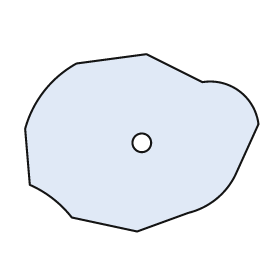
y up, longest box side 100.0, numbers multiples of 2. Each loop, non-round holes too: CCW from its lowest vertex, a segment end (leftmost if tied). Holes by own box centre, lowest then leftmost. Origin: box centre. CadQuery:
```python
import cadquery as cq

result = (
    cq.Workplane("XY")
    .moveTo(-2.0, -38.0)
    .lineTo(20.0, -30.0)
    .threePointArc((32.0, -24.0), (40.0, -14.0))
    .lineTo(50.0, 8.0)
    .threePointArc((42.0, 22.0), (26.0, 26.0))
    .lineTo(2.0, 38.0)
    .lineTo(-28.0, 34.0)
    .threePointArc((-42.0, 22.0), (-50.0, 6.0))
    .lineTo(-48.0, -18.0)
    .threePointArc((-38.0, -24.0), (-30.0, -32.0))
    .close()
    .moveTo(0.0, 0.0)
    .circle(4.0)
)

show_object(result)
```